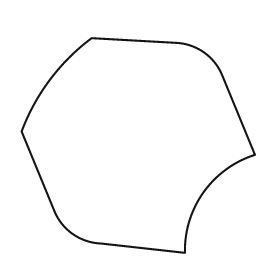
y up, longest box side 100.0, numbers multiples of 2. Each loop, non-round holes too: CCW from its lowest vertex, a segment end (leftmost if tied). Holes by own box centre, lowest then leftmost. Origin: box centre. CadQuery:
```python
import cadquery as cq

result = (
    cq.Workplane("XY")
    .moveTo(20.0, -46.0)
    .threePointArc((28.0, -20.0), (50.0, -4.0))
    .lineTo(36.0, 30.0)
    .threePointArc((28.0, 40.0), (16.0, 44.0))
    .lineTo(-20.0, 46.0)
    .threePointArc((-38.0, 28.0), (-50.0, 6.0))
    .lineTo(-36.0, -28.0)
    .threePointArc((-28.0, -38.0), (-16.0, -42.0))
    .close()
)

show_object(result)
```